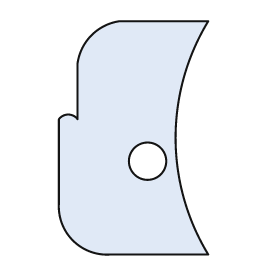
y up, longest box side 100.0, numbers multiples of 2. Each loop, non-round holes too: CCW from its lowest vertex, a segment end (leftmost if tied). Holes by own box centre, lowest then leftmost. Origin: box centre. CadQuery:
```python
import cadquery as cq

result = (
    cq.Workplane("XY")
    .moveTo(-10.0, -50.0)
    .lineTo(32.0, -50.0)
    .threePointArc((18.0, 0.0), (32.0, 50.0))
    .lineTo(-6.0, 50.0)
    .threePointArc((-18.0, 44.0), (-24.0, 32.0))
    .lineTo(-24.0, 8.0)
    .threePointArc((-28.0, 10.0), (-32.0, 8.0))
    .lineTo(-32.0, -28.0)
    .threePointArc((-26.0, -44.0), (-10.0, -50.0))
    .close()
    .moveTo(6.0, -10.0)
    .circle(8.0)
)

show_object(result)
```